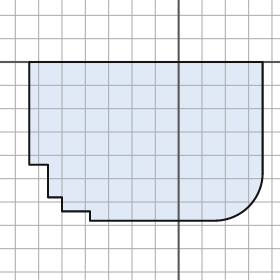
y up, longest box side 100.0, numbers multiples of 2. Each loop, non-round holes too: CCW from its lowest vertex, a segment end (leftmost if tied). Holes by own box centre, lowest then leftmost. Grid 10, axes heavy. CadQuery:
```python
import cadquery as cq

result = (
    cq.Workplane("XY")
    .moveTo(-38.0, -68.0)
    .lineTo(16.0, -68.0)
    .threePointArc((30.0, -62.0), (36.0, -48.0))
    .lineTo(36.0, 0.0)
    .lineTo(-64.0, 0.0)
    .lineTo(-64.0, -44.0)
    .lineTo(-56.0, -44.0)
    .lineTo(-56.0, -58.0)
    .lineTo(-50.0, -58.0)
    .lineTo(-50.0, -64.0)
    .lineTo(-38.0, -64.0)
    .close()
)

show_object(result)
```